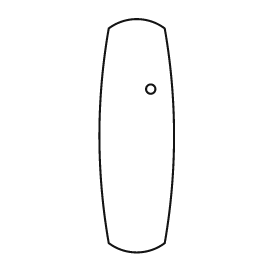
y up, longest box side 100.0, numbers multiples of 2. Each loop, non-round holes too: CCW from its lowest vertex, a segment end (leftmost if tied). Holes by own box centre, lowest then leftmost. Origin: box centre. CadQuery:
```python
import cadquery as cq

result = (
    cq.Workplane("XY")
    .moveTo(-12.0, -46.0)
    .threePointArc((0.0, -50.0), (12.0, -46.0))
    .threePointArc((16.0, 0.0), (12.0, 46.0))
    .threePointArc((0.0, 50.0), (-12.0, 46.0))
    .threePointArc((-16.0, 0.0), (-12.0, -46.0))
    .close()
    .moveTo(6.0, 20.0)
    .circle(2.0)
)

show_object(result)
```